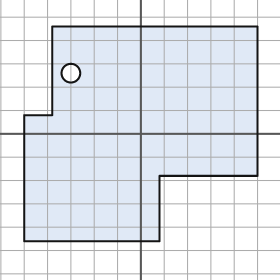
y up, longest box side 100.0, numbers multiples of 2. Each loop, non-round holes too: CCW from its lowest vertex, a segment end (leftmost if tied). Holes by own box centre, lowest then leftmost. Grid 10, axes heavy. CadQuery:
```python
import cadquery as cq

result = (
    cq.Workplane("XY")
    .moveTo(-50.0, -46.0)
    .lineTo(8.0, -46.0)
    .lineTo(8.0, -18.0)
    .lineTo(50.0, -18.0)
    .lineTo(50.0, 46.0)
    .lineTo(-38.0, 46.0)
    .lineTo(-38.0, 8.0)
    .lineTo(-50.0, 8.0)
    .close()
    .moveTo(-30.0, 26.0)
    .circle(4.0)
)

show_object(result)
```